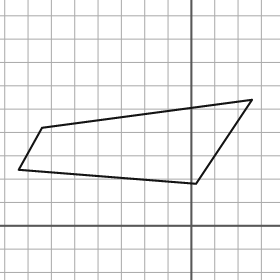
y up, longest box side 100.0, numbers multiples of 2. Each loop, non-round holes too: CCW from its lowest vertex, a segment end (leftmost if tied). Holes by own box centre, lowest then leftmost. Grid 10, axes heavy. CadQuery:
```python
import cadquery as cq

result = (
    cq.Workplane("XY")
    .moveTo(2.0, 18.0)
    .lineTo(26.0, 54.0)
    .lineTo(-64.0, 42.0)
    .lineTo(-74.0, 24.0)
    .close()
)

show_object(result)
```